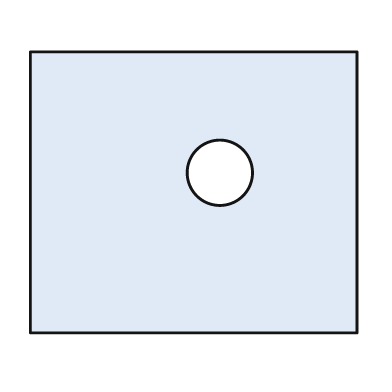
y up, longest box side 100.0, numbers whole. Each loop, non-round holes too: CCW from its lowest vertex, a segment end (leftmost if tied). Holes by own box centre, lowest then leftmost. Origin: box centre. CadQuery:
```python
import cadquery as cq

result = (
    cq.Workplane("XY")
    .moveTo(-50.0, -43.0)
    .lineTo(50.0, -43.0)
    .lineTo(50.0, 43.0)
    .lineTo(-50.0, 43.0)
    .close()
    .moveTo(8.0, 6.0)
    .circle(10.0)
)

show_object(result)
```